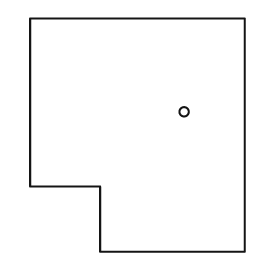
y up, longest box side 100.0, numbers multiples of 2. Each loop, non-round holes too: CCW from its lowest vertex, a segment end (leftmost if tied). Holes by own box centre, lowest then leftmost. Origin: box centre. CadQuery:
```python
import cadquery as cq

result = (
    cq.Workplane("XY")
    .moveTo(-16.0, -50.0)
    .lineTo(46.0, -50.0)
    .lineTo(46.0, 50.0)
    .lineTo(-46.0, 50.0)
    .lineTo(-46.0, -22.0)
    .lineTo(-16.0, -22.0)
    .close()
    .moveTo(20.0, 10.0)
    .circle(2.0)
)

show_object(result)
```